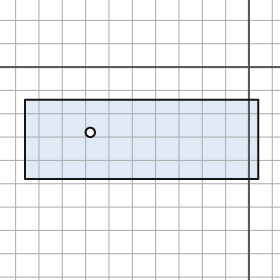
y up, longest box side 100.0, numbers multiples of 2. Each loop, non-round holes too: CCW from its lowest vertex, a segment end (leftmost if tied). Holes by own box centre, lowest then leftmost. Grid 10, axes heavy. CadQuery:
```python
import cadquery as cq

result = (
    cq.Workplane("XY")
    .moveTo(-96.0, -48.0)
    .lineTo(4.0, -48.0)
    .lineTo(4.0, -14.0)
    .lineTo(-96.0, -14.0)
    .close()
    .moveTo(-68.0, -28.0)
    .circle(2.0)
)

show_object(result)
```